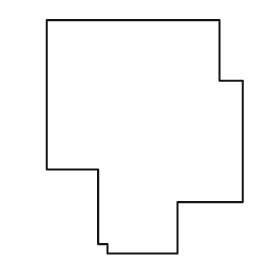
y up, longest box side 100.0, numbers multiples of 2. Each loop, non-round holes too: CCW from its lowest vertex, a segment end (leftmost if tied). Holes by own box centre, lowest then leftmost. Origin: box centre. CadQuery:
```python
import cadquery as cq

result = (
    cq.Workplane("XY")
    .moveTo(-16.0, -50.0)
    .lineTo(14.0, -50.0)
    .lineTo(14.0, -28.0)
    .lineTo(42.0, -28.0)
    .lineTo(42.0, 24.0)
    .lineTo(32.0, 24.0)
    .lineTo(32.0, 50.0)
    .lineTo(-42.0, 50.0)
    .lineTo(-42.0, -14.0)
    .lineTo(-20.0, -14.0)
    .lineTo(-20.0, -46.0)
    .lineTo(-16.0, -46.0)
    .close()
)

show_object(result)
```